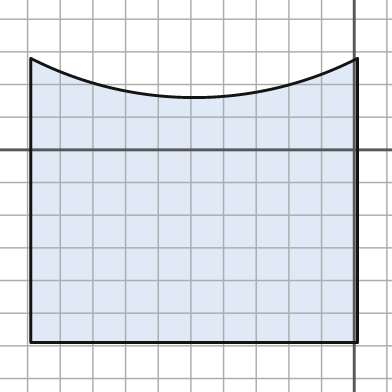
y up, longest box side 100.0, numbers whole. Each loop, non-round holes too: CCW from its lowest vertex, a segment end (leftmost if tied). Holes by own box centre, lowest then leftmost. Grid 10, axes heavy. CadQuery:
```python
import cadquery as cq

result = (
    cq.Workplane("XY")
    .moveTo(-99.0, -59.0)
    .lineTo(1.0, -59.0)
    .lineTo(1.0, 28.0)
    .threePointArc((-49.0, 16.0), (-99.0, 28.0))
    .close()
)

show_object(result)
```